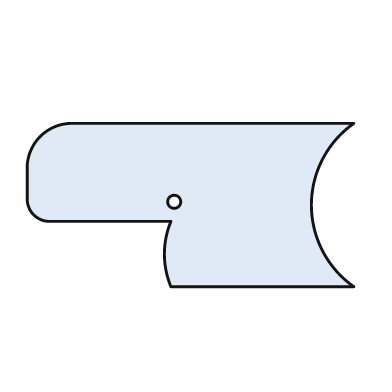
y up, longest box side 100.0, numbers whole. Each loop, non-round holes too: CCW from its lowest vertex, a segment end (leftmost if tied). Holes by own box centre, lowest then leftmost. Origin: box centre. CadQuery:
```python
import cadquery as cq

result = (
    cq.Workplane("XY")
    .moveTo(-6.0, -25.0)
    .lineTo(50.0, -25.0)
    .threePointArc((37.0, 0.0), (50.0, 25.0))
    .lineTo(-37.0, 25.0)
    .threePointArc((-46.0, 21.0), (-50.0, 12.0))
    .lineTo(-50.0, 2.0)
    .threePointArc((-48.0, -3.0), (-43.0, -5.0))
    .lineTo(-6.0, -5.0)
    .threePointArc((-8.0, -15.0), (-6.0, -25.0))
    .close()
    .moveTo(-5.0, 1.0)
    .circle(2.0)
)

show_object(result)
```